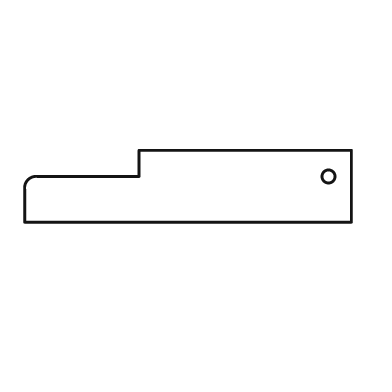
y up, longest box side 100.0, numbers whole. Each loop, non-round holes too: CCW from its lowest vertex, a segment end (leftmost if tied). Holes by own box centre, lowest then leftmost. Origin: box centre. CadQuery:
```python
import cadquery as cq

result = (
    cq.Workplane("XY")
    .moveTo(-50.0, -11.0)
    .lineTo(50.0, -11.0)
    .lineTo(50.0, 11.0)
    .lineTo(-15.0, 11.0)
    .lineTo(-15.0, 3.0)
    .lineTo(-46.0, 3.0)
    .threePointArc((-49.0, 2.0), (-50.0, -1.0))
    .close()
    .moveTo(43.0, 3.0)
    .circle(2.0)
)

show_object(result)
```